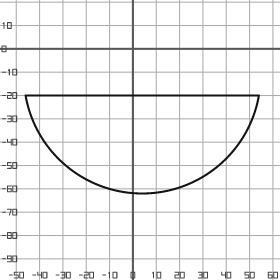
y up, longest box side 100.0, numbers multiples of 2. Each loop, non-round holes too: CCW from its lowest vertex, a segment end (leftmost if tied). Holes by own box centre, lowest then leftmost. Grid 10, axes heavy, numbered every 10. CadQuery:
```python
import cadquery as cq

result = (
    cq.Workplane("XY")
    .moveTo(-46.0, -20.0)
    .threePointArc((4.0, -62.0), (54.0, -20.0))
    .close()
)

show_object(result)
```